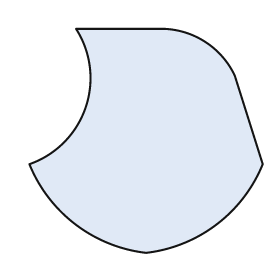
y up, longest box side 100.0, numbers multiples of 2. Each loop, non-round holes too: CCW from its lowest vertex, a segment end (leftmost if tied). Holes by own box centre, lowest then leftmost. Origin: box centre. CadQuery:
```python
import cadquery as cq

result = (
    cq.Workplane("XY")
    .moveTo(0.0, -48.0)
    .threePointArc((30.0, -36.0), (50.0, -10.0))
    .lineTo(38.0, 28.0)
    .threePointArc((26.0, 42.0), (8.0, 48.0))
    .lineTo(-30.0, 48.0)
    .threePointArc((-26.0, 14.0), (-50.0, -10.0))
    .threePointArc((-30.0, -36.0), (0.0, -48.0))
    .close()
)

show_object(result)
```